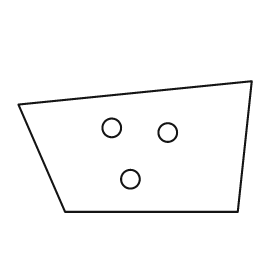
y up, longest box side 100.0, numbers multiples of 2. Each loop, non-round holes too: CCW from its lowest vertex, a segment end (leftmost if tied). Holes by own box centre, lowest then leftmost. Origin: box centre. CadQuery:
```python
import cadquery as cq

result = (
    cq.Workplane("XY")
    .moveTo(-30.0, -28.0)
    .lineTo(44.0, -28.0)
    .lineTo(50.0, 28.0)
    .lineTo(-50.0, 18.0)
    .close()
    .moveTo(-2.0, -14.0)
    .circle(4.0)
    .moveTo(14.0, 6.0)
    .circle(4.0)
    .moveTo(-10.0, 8.0)
    .circle(4.0)
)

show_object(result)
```